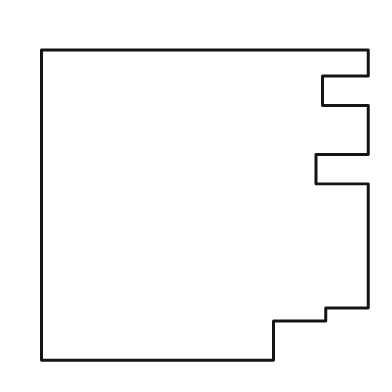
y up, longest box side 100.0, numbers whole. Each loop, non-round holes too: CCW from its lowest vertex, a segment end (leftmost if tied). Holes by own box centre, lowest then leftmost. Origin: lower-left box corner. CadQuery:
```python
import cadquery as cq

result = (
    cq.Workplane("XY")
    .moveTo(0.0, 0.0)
    .lineTo(71.0, 0.0)
    .lineTo(71.0, 12.0)
    .lineTo(87.0, 12.0)
    .lineTo(87.0, 16.0)
    .lineTo(100.0, 16.0)
    .lineTo(100.0, 54.0)
    .lineTo(84.0, 54.0)
    .lineTo(84.0, 63.0)
    .lineTo(100.0, 63.0)
    .lineTo(100.0, 78.0)
    .lineTo(86.0, 78.0)
    .lineTo(86.0, 87.0)
    .lineTo(100.0, 87.0)
    .lineTo(100.0, 95.0)
    .lineTo(0.0, 95.0)
    .close()
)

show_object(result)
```